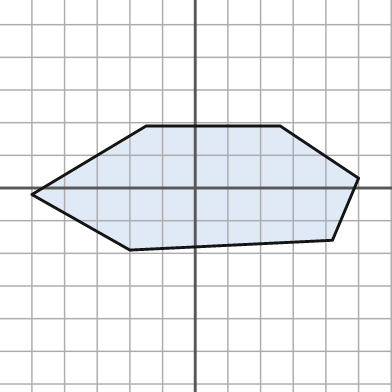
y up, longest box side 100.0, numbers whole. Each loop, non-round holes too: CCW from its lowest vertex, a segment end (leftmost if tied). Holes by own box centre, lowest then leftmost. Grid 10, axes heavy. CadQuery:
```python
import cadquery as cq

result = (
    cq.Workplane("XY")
    .moveTo(-20.0, -19.0)
    .lineTo(42.0, -16.0)
    .lineTo(50.0, 3.0)
    .lineTo(26.0, 19.0)
    .lineTo(-15.0, 19.0)
    .lineTo(-50.0, -2.0)
    .close()
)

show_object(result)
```